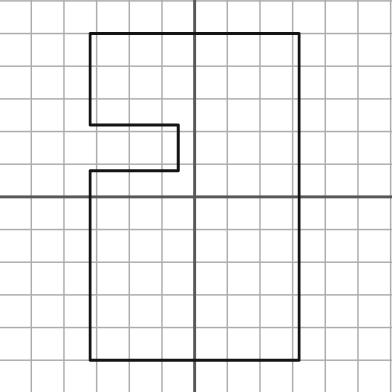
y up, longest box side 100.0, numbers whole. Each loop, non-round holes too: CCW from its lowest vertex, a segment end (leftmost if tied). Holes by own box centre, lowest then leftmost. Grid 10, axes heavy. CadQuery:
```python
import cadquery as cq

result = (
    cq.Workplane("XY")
    .moveTo(-32.0, -50.0)
    .lineTo(32.0, -50.0)
    .lineTo(32.0, 50.0)
    .lineTo(-32.0, 50.0)
    .lineTo(-32.0, 22.0)
    .lineTo(-5.0, 22.0)
    .lineTo(-5.0, 8.0)
    .lineTo(-32.0, 8.0)
    .close()
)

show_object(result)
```